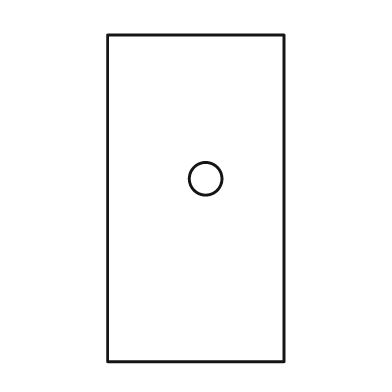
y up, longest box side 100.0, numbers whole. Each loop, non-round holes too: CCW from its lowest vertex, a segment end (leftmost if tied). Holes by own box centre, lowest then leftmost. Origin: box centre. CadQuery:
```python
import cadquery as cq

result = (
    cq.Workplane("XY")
    .moveTo(-27.0, -50.0)
    .lineTo(27.0, -50.0)
    .lineTo(27.0, 50.0)
    .lineTo(-27.0, 50.0)
    .close()
    .moveTo(3.0, 6.0)
    .circle(5.0)
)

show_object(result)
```